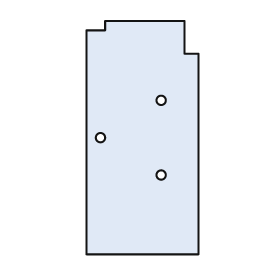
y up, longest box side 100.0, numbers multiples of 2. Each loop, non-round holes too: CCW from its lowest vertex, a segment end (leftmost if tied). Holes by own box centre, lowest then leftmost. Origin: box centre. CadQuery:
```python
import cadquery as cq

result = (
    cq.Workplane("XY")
    .moveTo(-24.0, -50.0)
    .lineTo(24.0, -50.0)
    .lineTo(24.0, 36.0)
    .lineTo(18.0, 36.0)
    .lineTo(18.0, 50.0)
    .lineTo(-16.0, 50.0)
    .lineTo(-16.0, 46.0)
    .lineTo(-24.0, 46.0)
    .close()
    .moveTo(8.0, -16.0)
    .circle(2.0)
    .moveTo(-18.0, 0.0)
    .circle(2.0)
    .moveTo(8.0, 16.0)
    .circle(2.0)
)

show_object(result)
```